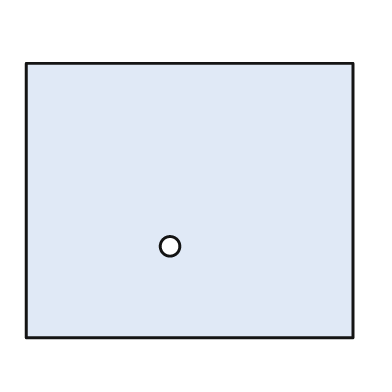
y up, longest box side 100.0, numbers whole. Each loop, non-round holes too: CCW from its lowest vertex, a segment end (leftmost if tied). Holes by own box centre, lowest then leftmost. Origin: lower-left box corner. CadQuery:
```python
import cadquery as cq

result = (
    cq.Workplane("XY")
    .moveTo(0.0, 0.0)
    .lineTo(100.0, 0.0)
    .lineTo(100.0, 84.0)
    .lineTo(0.0, 84.0)
    .close()
    .moveTo(44.0, 28.0)
    .circle(3.0)
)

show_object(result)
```